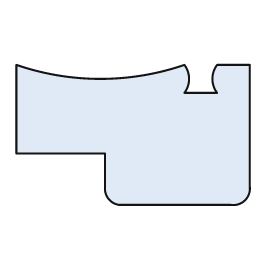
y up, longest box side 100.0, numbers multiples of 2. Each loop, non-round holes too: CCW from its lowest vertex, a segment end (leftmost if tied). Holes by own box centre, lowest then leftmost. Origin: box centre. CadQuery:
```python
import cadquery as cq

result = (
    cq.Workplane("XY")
    .moveTo(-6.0, -30.0)
    .lineTo(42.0, -30.0)
    .threePointArc((48.0, -28.0), (50.0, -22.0))
    .lineTo(50.0, 30.0)
    .lineTo(36.0, 30.0)
    .threePointArc((34.0, 24.0), (36.0, 18.0))
    .lineTo(22.0, 18.0)
    .threePointArc((24.0, 24.0), (22.0, 30.0))
    .threePointArc((-14.0, 24.0), (-50.0, 30.0))
    .lineTo(-50.0, -8.0)
    .lineTo(-12.0, -8.0)
    .lineTo(-12.0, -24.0)
    .threePointArc((-10.0, -28.0), (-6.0, -30.0))
    .close()
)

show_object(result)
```